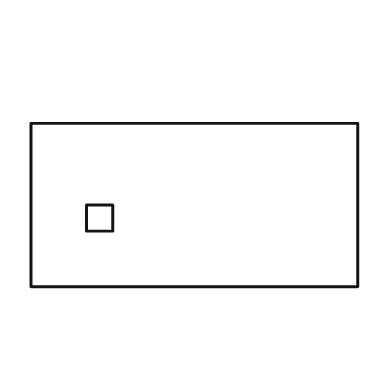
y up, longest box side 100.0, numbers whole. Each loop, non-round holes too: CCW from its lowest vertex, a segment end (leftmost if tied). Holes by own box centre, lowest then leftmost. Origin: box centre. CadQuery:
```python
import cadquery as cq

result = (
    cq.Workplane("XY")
    .moveTo(-50.0, -25.0)
    .lineTo(50.0, -25.0)
    .lineTo(50.0, 25.0)
    .lineTo(-50.0, 25.0)
    .close()
    .moveTo(-33.0, -8.0)
    .lineTo(-25.0, -8.0)
    .lineTo(-25.0, 0.0)
    .lineTo(-33.0, 0.0)
    .close()
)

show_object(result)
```